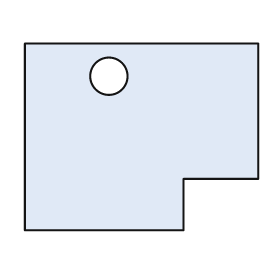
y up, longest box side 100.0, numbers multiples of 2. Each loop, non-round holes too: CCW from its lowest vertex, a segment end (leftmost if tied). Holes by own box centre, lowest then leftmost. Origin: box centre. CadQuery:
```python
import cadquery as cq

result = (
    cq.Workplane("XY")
    .moveTo(-50.0, -40.0)
    .lineTo(18.0, -40.0)
    .lineTo(18.0, -18.0)
    .lineTo(50.0, -18.0)
    .lineTo(50.0, 40.0)
    .lineTo(-50.0, 40.0)
    .close()
    .moveTo(-14.0, 26.0)
    .circle(8.0)
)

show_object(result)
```